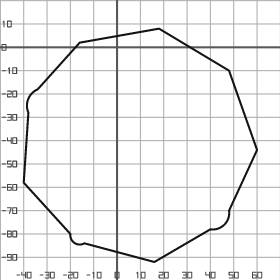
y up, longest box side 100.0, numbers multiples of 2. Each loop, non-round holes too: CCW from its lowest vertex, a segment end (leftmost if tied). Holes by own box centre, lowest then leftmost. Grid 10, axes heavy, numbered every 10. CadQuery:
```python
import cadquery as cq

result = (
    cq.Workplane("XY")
    .moveTo(16.0, -92.0)
    .lineTo(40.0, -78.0)
    .threePointArc((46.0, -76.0), (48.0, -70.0))
    .lineTo(60.0, -44.0)
    .lineTo(48.0, -10.0)
    .lineTo(18.0, 8.0)
    .lineTo(-16.0, 2.0)
    .lineTo(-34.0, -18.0)
    .threePointArc((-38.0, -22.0), (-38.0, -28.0))
    .lineTo(-40.0, -58.0)
    .lineTo(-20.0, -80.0)
    .threePointArc((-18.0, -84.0), (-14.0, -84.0))
    .close()
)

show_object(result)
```